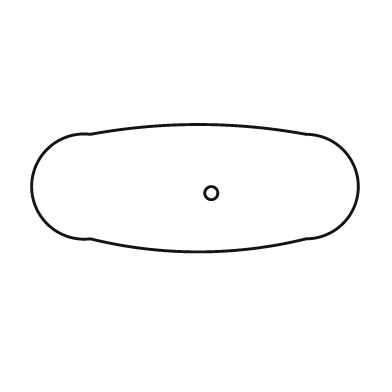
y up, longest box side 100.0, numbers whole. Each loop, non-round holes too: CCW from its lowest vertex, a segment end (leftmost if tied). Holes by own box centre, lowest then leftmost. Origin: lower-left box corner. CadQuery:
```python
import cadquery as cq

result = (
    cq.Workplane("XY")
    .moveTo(18.0, 4.0)
    .threePointArc((51.0, 0.0), (84.0, 4.0))
    .threePointArc((100.0, 20.0), (84.0, 36.0))
    .threePointArc((51.0, 39.0), (18.0, 36.0))
    .threePointArc((0.0, 20.0), (18.0, 4.0))
    .close()
    .moveTo(55.0, 18.0)
    .circle(2.0)
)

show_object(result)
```